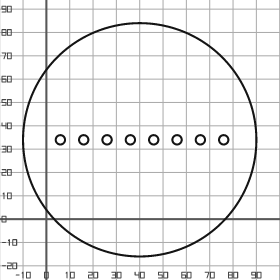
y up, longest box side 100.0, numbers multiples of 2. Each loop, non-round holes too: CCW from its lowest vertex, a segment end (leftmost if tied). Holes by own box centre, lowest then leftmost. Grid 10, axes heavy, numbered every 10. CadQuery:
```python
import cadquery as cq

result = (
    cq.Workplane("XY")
    .moveTo(40.0, 34.0)
    .circle(50.0)
    .moveTo(6.0, 34.0)
    .circle(2.0)
    .moveTo(16.0, 34.0)
    .circle(2.0)
    .moveTo(26.0, 34.0)
    .circle(2.0)
    .moveTo(36.0, 34.0)
    .circle(2.0)
    .moveTo(46.0, 34.0)
    .circle(2.0)
    .moveTo(56.0, 34.0)
    .circle(2.0)
    .moveTo(66.0, 34.0)
    .circle(2.0)
    .moveTo(76.0, 34.0)
    .circle(2.0)
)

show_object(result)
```